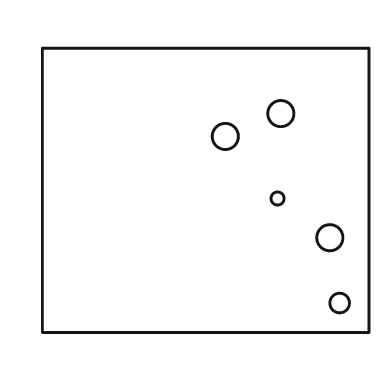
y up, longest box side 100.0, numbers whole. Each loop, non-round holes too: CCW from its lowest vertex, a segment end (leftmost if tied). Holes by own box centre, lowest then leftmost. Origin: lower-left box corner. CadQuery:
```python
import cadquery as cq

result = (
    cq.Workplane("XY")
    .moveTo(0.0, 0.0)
    .lineTo(100.0, 0.0)
    .lineTo(100.0, 87.0)
    .lineTo(0.0, 87.0)
    .close()
    .moveTo(91.0, 9.0)
    .circle(3.0)
    .moveTo(88.0, 29.0)
    .circle(4.0)
    .moveTo(72.0, 41.0)
    .circle(2.0)
    .moveTo(56.0, 60.0)
    .circle(4.0)
    .moveTo(73.0, 67.0)
    .circle(4.0)
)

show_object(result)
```